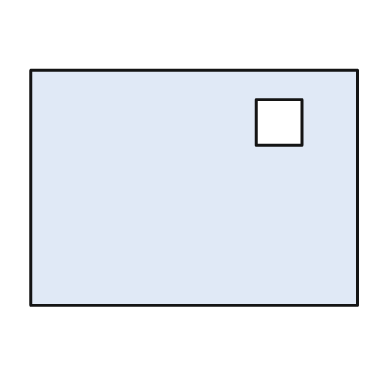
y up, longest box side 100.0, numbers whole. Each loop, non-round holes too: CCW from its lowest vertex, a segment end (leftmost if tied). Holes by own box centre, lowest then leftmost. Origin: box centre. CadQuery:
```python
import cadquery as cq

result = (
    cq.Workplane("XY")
    .moveTo(-50.0, -36.0)
    .lineTo(50.0, -36.0)
    .lineTo(50.0, 36.0)
    .lineTo(-50.0, 36.0)
    .close()
    .moveTo(19.0, 13.0)
    .lineTo(33.0, 13.0)
    .lineTo(33.0, 27.0)
    .lineTo(19.0, 27.0)
    .close()
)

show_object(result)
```